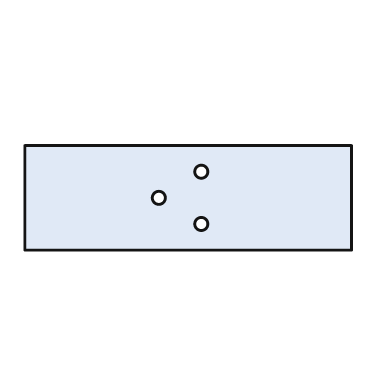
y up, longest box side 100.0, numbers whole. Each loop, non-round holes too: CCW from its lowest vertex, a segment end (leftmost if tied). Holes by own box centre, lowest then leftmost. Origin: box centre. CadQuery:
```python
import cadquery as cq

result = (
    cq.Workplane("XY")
    .moveTo(-50.0, -16.0)
    .lineTo(50.0, -16.0)
    .lineTo(50.0, 16.0)
    .lineTo(-50.0, 16.0)
    .close()
    .moveTo(4.0, -8.0)
    .circle(2.0)
    .moveTo(-9.0, 0.0)
    .circle(2.0)
    .moveTo(4.0, 8.0)
    .circle(2.0)
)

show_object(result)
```